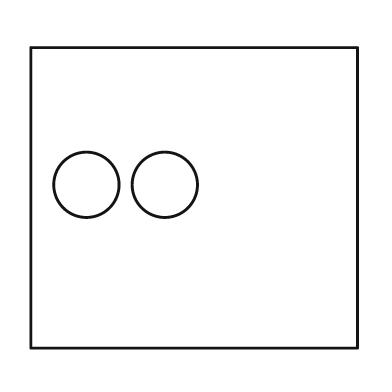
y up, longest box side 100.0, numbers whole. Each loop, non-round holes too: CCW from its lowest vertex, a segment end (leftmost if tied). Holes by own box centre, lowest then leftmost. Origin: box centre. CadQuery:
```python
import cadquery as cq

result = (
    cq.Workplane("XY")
    .moveTo(-50.0, -46.0)
    .lineTo(50.0, -46.0)
    .lineTo(50.0, 46.0)
    .lineTo(-50.0, 46.0)
    .close()
    .moveTo(-33.0, 4.0)
    .circle(10.0)
    .moveTo(-9.0, 4.0)
    .circle(10.0)
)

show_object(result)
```